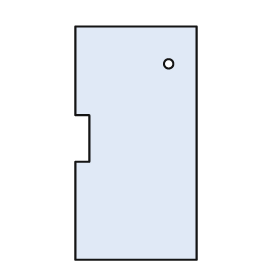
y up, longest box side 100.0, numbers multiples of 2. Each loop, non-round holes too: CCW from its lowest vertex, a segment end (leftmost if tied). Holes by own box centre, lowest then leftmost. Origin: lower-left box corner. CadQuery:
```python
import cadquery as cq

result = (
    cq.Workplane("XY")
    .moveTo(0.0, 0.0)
    .lineTo(52.0, 0.0)
    .lineTo(52.0, 100.0)
    .lineTo(0.0, 100.0)
    .lineTo(0.0, 62.0)
    .lineTo(6.0, 62.0)
    .lineTo(6.0, 42.0)
    .lineTo(0.0, 42.0)
    .close()
    .moveTo(40.0, 84.0)
    .circle(2.0)
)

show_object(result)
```